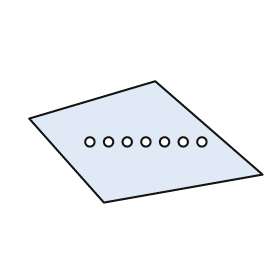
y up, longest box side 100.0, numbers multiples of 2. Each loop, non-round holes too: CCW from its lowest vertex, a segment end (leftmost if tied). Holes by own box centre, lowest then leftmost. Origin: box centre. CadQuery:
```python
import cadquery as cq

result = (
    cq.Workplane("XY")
    .moveTo(-18.0, -26.0)
    .lineTo(50.0, -14.0)
    .lineTo(4.0, 26.0)
    .lineTo(-50.0, 10.0)
    .close()
    .moveTo(-24.0, 0.0)
    .circle(2.0)
    .moveTo(-16.0, 0.0)
    .circle(2.0)
    .moveTo(-8.0, 0.0)
    .circle(2.0)
    .moveTo(0.0, 0.0)
    .circle(2.0)
    .moveTo(8.0, 0.0)
    .circle(2.0)
    .moveTo(16.0, 0.0)
    .circle(2.0)
    .moveTo(24.0, 0.0)
    .circle(2.0)
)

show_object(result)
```